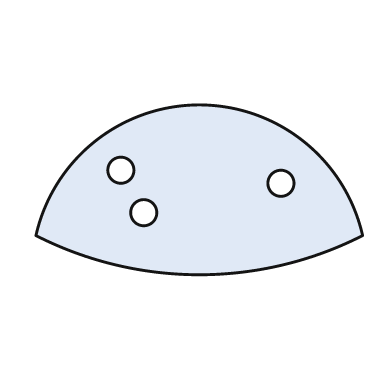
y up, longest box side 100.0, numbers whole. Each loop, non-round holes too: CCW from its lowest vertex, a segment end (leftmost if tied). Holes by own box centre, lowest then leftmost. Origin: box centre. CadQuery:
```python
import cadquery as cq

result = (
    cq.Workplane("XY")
    .moveTo(-50.0, -14.0)
    .threePointArc((0.0, -26.0), (50.0, -14.0))
    .threePointArc((0.0, 26.0), (-50.0, -14.0))
    .close()
    .moveTo(-17.0, -7.0)
    .circle(4.0)
    .moveTo(25.0, 2.0)
    .circle(4.0)
    .moveTo(-24.0, 6.0)
    .circle(4.0)
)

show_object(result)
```